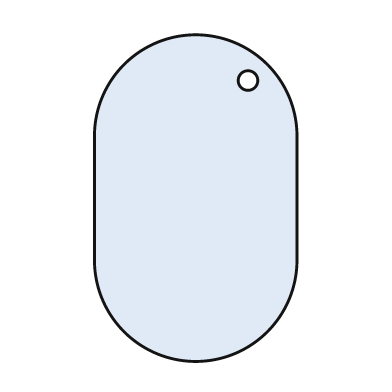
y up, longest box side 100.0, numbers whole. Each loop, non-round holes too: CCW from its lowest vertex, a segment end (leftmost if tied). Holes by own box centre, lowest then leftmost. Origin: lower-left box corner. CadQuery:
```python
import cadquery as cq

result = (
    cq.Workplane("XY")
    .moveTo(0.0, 31.0)
    .threePointArc((31.0, 0.0), (62.0, 31.0))
    .lineTo(62.0, 69.0)
    .threePointArc((31.0, 100.0), (0.0, 69.0))
    .close()
    .moveTo(47.0, 86.0)
    .circle(3.0)
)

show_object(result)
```